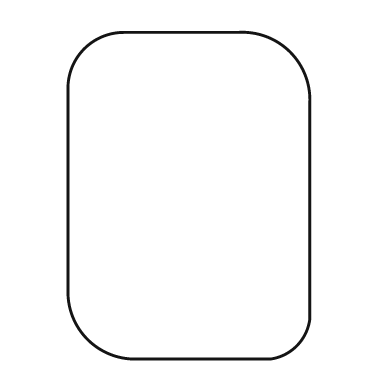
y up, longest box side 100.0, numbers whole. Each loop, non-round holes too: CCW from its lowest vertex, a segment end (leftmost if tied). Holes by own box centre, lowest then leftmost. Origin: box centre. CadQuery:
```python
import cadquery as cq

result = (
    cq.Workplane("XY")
    .moveTo(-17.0, -50.0)
    .lineTo(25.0, -50.0)
    .threePointArc((33.0, -46.0), (37.0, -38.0))
    .lineTo(37.0, 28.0)
    .threePointArc((31.0, 44.0), (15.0, 50.0))
    .lineTo(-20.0, 50.0)
    .threePointArc((-32.0, 45.0), (-37.0, 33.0))
    .lineTo(-37.0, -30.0)
    .threePointArc((-31.0, -44.0), (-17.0, -50.0))
    .close()
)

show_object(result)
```